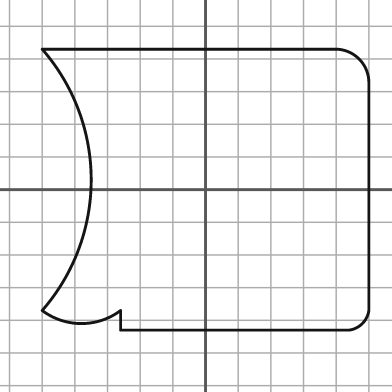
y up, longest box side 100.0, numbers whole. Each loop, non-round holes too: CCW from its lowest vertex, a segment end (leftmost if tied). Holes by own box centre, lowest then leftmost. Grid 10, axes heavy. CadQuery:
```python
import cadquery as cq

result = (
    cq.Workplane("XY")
    .moveTo(-26.0, -43.0)
    .lineTo(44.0, -43.0)
    .threePointArc((48.0, -41.0), (50.0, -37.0))
    .lineTo(50.0, 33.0)
    .threePointArc((47.0, 40.0), (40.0, 43.0))
    .lineTo(-50.0, 43.0)
    .threePointArc((-35.0, 3.0), (-50.0, -37.0))
    .threePointArc((-38.0, -41.0), (-26.0, -37.0))
    .close()
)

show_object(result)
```